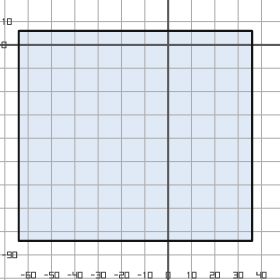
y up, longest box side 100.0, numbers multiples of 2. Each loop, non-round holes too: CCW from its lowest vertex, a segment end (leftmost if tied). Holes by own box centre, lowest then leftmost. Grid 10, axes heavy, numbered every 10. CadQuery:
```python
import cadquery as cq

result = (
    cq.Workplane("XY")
    .moveTo(-64.0, -84.0)
    .lineTo(36.0, -84.0)
    .lineTo(36.0, 6.0)
    .lineTo(-64.0, 6.0)
    .close()
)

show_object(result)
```